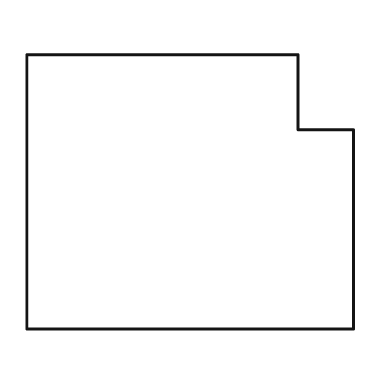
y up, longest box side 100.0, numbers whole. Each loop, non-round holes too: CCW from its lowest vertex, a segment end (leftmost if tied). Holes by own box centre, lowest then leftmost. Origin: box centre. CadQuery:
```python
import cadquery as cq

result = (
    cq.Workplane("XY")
    .moveTo(-50.0, -42.0)
    .lineTo(50.0, -42.0)
    .lineTo(50.0, 19.0)
    .lineTo(33.0, 19.0)
    .lineTo(33.0, 42.0)
    .lineTo(-50.0, 42.0)
    .close()
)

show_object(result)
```